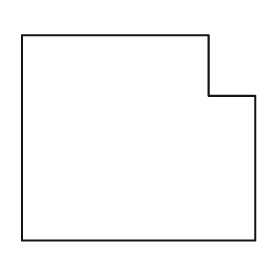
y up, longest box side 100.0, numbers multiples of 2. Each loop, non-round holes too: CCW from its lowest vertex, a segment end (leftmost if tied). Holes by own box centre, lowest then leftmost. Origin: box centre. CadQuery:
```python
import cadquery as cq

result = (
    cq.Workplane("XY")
    .moveTo(-50.0, -44.0)
    .lineTo(50.0, -44.0)
    .lineTo(50.0, 18.0)
    .lineTo(30.0, 18.0)
    .lineTo(30.0, 44.0)
    .lineTo(-50.0, 44.0)
    .close()
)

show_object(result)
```